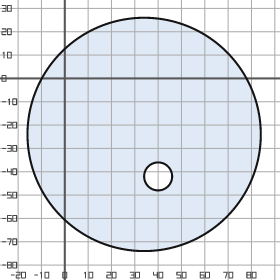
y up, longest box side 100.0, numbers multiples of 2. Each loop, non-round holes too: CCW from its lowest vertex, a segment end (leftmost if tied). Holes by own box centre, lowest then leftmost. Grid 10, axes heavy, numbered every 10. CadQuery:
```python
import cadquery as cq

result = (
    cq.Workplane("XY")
    .moveTo(34.0, -24.0)
    .circle(50.0)
    .moveTo(40.0, -42.0)
    .circle(6.0)
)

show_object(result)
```